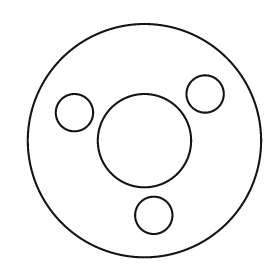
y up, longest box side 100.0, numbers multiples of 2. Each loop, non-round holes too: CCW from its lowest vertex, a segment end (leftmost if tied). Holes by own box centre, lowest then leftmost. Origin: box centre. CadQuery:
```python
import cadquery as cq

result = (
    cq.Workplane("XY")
    .moveTo(0.0, 0.0)
    .circle(50.0)
    .moveTo(4.0, -32.0)
    .circle(8.0)
    .moveTo(0.0, 0.0)
    .circle(20.0)
    .moveTo(-30.0, 12.0)
    .circle(8.0)
    .moveTo(26.0, 20.0)
    .circle(8.0)
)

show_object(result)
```